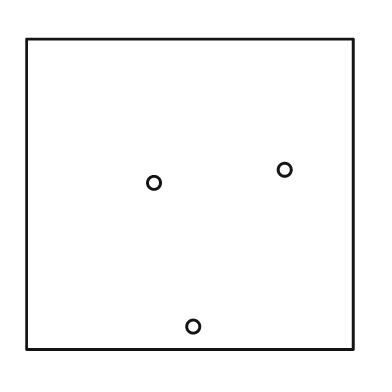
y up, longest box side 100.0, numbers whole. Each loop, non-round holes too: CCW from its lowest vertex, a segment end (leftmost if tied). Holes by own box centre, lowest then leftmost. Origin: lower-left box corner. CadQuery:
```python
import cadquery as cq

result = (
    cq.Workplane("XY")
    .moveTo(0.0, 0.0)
    .lineTo(100.0, 0.0)
    .lineTo(100.0, 95.0)
    .lineTo(0.0, 95.0)
    .close()
    .moveTo(51.0, 7.0)
    .circle(2.0)
    .moveTo(39.0, 51.0)
    .circle(2.0)
    .moveTo(79.0, 55.0)
    .circle(2.0)
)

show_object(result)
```